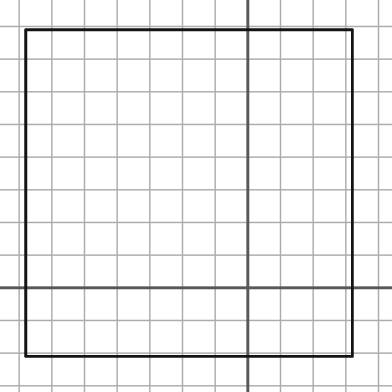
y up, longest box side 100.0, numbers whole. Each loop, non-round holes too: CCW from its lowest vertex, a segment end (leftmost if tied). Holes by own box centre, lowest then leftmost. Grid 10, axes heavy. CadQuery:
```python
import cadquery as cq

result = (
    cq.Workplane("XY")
    .moveTo(-68.0, -21.0)
    .lineTo(32.0, -21.0)
    .lineTo(32.0, 79.0)
    .lineTo(-68.0, 79.0)
    .close()
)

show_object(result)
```